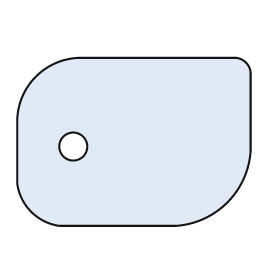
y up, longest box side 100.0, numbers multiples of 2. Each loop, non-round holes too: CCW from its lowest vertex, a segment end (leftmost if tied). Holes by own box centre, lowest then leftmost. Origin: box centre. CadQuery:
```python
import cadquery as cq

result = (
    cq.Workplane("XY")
    .moveTo(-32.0, -36.0)
    .lineTo(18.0, -36.0)
    .threePointArc((40.0, -26.0), (50.0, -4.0))
    .lineTo(50.0, 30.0)
    .threePointArc((48.0, 34.0), (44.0, 36.0))
    .lineTo(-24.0, 36.0)
    .threePointArc((-42.0, 28.0), (-50.0, 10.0))
    .lineTo(-50.0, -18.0)
    .threePointArc((-44.0, -30.0), (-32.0, -36.0))
    .close()
    .moveTo(-26.0, -2.0)
    .circle(6.0)
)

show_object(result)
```